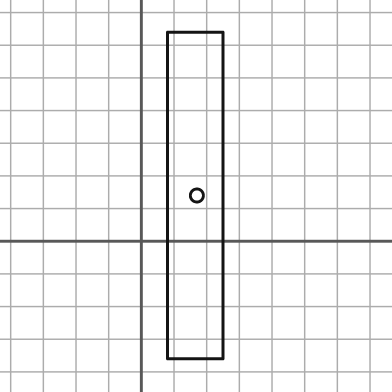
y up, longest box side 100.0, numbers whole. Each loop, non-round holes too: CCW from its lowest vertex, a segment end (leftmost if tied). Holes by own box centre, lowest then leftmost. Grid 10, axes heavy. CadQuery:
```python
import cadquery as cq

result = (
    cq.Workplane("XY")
    .moveTo(8.0, -36.0)
    .lineTo(25.0, -36.0)
    .lineTo(25.0, 64.0)
    .lineTo(8.0, 64.0)
    .close()
    .moveTo(17.0, 14.0)
    .circle(2.0)
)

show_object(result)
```